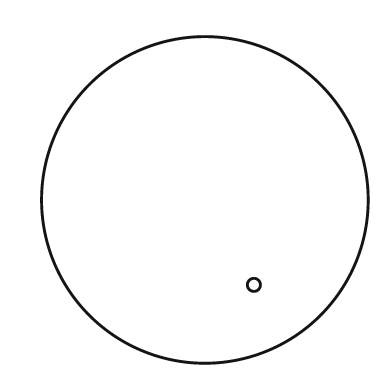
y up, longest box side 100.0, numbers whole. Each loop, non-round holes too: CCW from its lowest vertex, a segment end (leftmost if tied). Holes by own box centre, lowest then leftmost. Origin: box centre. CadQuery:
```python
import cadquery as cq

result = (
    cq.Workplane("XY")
    .moveTo(0.0, 0.0)
    .circle(50.0)
    .moveTo(15.0, -26.0)
    .circle(2.0)
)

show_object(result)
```